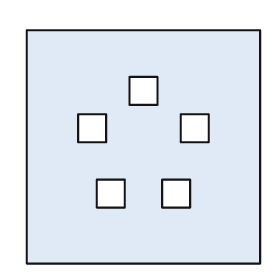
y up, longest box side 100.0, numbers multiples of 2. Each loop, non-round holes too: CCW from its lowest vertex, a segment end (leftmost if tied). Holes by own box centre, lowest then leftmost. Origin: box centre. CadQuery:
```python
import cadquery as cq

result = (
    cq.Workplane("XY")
    .moveTo(-50.0, -50.0)
    .lineTo(50.0, -50.0)
    .lineTo(50.0, 50.0)
    .lineTo(-50.0, 50.0)
    .close()
    .moveTo(-20.0, -26.0)
    .lineTo(-8.0, -26.0)
    .lineTo(-8.0, -14.0)
    .lineTo(-20.0, -14.0)
    .close()
    .moveTo(8.0, -26.0)
    .lineTo(20.0, -26.0)
    .lineTo(20.0, -14.0)
    .lineTo(8.0, -14.0)
    .close()
    .moveTo(-28.0, 2.0)
    .lineTo(-16.0, 2.0)
    .lineTo(-16.0, 14.0)
    .lineTo(-28.0, 14.0)
    .close()
    .moveTo(16.0, 2.0)
    .lineTo(28.0, 2.0)
    .lineTo(28.0, 14.0)
    .lineTo(16.0, 14.0)
    .close()
    .moveTo(-6.0, 18.0)
    .lineTo(6.0, 18.0)
    .lineTo(6.0, 30.0)
    .lineTo(-6.0, 30.0)
    .close()
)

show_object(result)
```